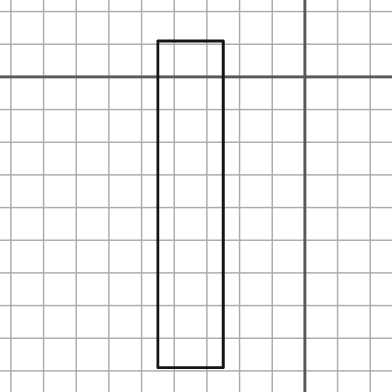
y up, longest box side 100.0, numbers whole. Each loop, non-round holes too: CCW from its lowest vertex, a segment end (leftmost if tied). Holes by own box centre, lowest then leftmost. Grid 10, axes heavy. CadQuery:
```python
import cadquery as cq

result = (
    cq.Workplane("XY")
    .moveTo(-45.0, -89.0)
    .lineTo(-25.0, -89.0)
    .lineTo(-25.0, 11.0)
    .lineTo(-45.0, 11.0)
    .close()
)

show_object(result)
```